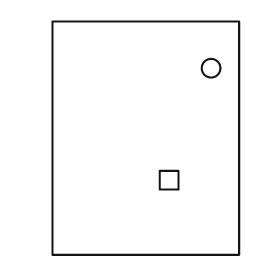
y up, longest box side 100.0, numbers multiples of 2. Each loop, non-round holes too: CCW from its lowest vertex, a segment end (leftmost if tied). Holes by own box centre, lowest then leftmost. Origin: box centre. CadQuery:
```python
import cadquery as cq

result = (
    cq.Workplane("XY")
    .moveTo(-40.0, -50.0)
    .lineTo(40.0, -50.0)
    .lineTo(40.0, 50.0)
    .lineTo(-40.0, 50.0)
    .close()
    .moveTo(6.0, -22.0)
    .lineTo(14.0, -22.0)
    .lineTo(14.0, -14.0)
    .lineTo(6.0, -14.0)
    .close()
    .moveTo(28.0, 30.0)
    .circle(4.0)
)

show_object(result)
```